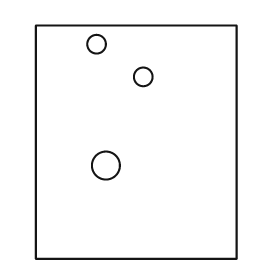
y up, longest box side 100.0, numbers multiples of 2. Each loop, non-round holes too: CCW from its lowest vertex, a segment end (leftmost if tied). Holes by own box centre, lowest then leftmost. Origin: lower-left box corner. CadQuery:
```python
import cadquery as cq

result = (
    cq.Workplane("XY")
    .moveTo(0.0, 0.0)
    .lineTo(86.0, 0.0)
    .lineTo(86.0, 100.0)
    .lineTo(0.0, 100.0)
    .close()
    .moveTo(30.0, 40.0)
    .circle(6.0)
    .moveTo(46.0, 78.0)
    .circle(4.0)
    .moveTo(26.0, 92.0)
    .circle(4.0)
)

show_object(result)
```